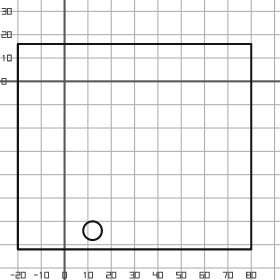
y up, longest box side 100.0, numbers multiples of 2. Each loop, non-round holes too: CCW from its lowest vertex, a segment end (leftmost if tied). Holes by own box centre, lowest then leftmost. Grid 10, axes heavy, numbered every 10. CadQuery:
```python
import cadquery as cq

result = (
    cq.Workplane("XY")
    .moveTo(-20.0, -72.0)
    .lineTo(80.0, -72.0)
    .lineTo(80.0, 16.0)
    .lineTo(-20.0, 16.0)
    .close()
    .moveTo(12.0, -64.0)
    .circle(4.0)
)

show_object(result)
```